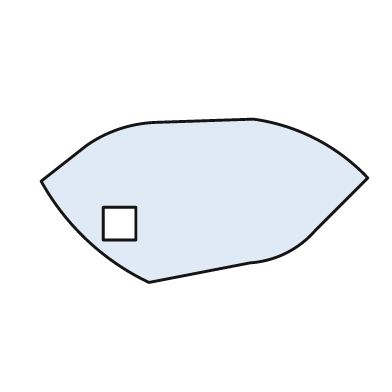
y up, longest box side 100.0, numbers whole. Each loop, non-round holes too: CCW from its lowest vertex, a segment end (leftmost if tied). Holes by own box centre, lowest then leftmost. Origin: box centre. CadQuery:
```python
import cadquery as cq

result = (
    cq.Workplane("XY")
    .moveTo(-17.0, -25.0)
    .lineTo(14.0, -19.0)
    .threePointArc((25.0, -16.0), (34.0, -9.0))
    .lineTo(50.0, 7.0)
    .threePointArc((34.0, 19.0), (15.0, 25.0))
    .lineTo(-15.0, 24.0)
    .threePointArc((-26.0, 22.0), (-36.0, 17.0))
    .lineTo(-50.0, 6.0)
    .threePointArc((-36.0, -12.0), (-17.0, -25.0))
    .close()
    .moveTo(-31.0, -12.0)
    .lineTo(-21.0, -12.0)
    .lineTo(-21.0, -2.0)
    .lineTo(-31.0, -2.0)
    .close()
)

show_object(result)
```